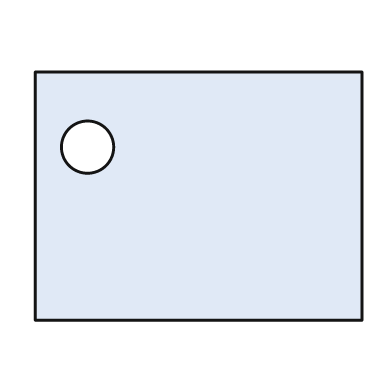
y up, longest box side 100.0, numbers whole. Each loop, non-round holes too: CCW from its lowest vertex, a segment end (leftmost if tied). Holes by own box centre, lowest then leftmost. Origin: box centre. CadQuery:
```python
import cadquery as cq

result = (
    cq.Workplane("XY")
    .moveTo(-50.0, -38.0)
    .lineTo(50.0, -38.0)
    .lineTo(50.0, 38.0)
    .lineTo(-50.0, 38.0)
    .close()
    .moveTo(-34.0, 15.0)
    .circle(8.0)
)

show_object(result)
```